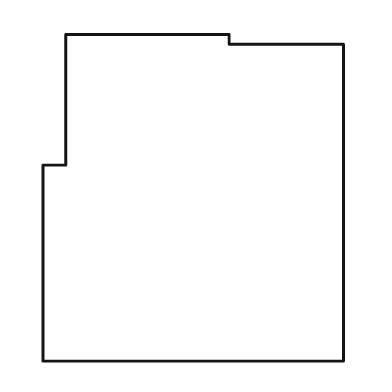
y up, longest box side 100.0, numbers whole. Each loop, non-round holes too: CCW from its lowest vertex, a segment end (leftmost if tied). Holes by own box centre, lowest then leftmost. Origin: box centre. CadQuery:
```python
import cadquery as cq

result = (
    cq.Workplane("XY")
    .moveTo(-46.0, -50.0)
    .lineTo(46.0, -50.0)
    .lineTo(46.0, 47.0)
    .lineTo(11.0, 47.0)
    .lineTo(11.0, 50.0)
    .lineTo(-39.0, 50.0)
    .lineTo(-39.0, 10.0)
    .lineTo(-46.0, 10.0)
    .close()
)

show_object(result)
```